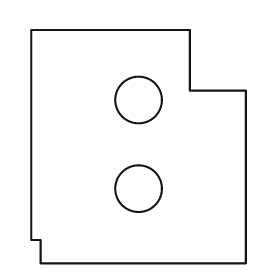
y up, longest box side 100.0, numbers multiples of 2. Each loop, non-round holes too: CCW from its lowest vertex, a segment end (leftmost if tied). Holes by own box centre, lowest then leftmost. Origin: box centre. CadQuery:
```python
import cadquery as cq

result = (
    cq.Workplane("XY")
    .moveTo(-42.0, -50.0)
    .lineTo(46.0, -50.0)
    .lineTo(46.0, 24.0)
    .lineTo(22.0, 24.0)
    .lineTo(22.0, 50.0)
    .lineTo(-46.0, 50.0)
    .lineTo(-46.0, -40.0)
    .lineTo(-42.0, -40.0)
    .close()
    .moveTo(0.0, -18.0)
    .circle(10.0)
    .moveTo(0.0, 20.0)
    .circle(10.0)
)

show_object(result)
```